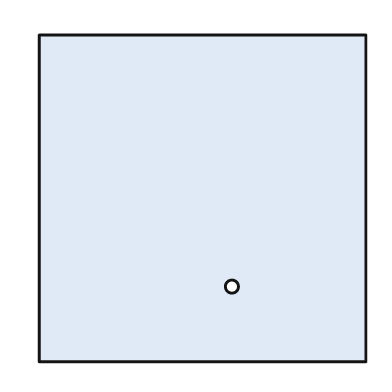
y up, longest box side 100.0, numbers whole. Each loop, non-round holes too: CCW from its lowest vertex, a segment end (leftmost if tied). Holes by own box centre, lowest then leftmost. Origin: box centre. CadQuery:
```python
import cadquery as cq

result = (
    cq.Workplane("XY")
    .moveTo(-50.0, -50.0)
    .lineTo(50.0, -50.0)
    .lineTo(50.0, 50.0)
    .lineTo(-50.0, 50.0)
    .close()
    .moveTo(9.0, -27.0)
    .circle(2.0)
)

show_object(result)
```